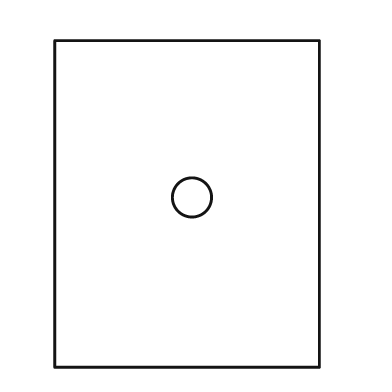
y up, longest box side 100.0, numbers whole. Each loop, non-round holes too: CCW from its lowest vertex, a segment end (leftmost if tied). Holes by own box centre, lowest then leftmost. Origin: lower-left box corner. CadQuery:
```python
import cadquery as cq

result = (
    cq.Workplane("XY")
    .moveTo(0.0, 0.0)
    .lineTo(81.0, 0.0)
    .lineTo(81.0, 100.0)
    .lineTo(0.0, 100.0)
    .close()
    .moveTo(42.0, 52.0)
    .circle(6.0)
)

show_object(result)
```